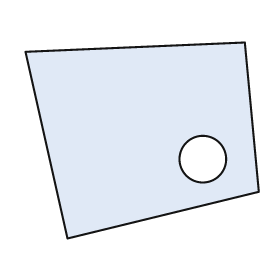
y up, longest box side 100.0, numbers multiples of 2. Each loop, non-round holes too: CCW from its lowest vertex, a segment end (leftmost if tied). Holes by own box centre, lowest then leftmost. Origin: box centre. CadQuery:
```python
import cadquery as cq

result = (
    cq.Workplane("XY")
    .moveTo(-32.0, -42.0)
    .lineTo(50.0, -22.0)
    .lineTo(44.0, 42.0)
    .lineTo(-50.0, 38.0)
    .close()
    .moveTo(26.0, -8.0)
    .circle(10.0)
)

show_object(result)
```